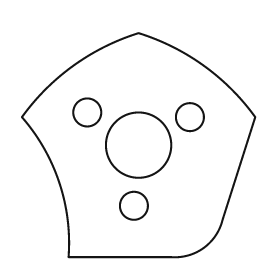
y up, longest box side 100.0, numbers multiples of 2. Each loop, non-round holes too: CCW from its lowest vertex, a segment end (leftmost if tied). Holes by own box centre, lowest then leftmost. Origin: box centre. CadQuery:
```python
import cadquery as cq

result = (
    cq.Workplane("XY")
    .moveTo(-30.0, -48.0)
    .lineTo(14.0, -48.0)
    .threePointArc((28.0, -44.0), (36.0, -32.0))
    .lineTo(50.0, 12.0)
    .threePointArc((28.0, 34.0), (0.0, 48.0))
    .threePointArc((-28.0, 34.0), (-50.0, 12.0))
    .threePointArc((-34.0, -16.0), (-30.0, -48.0))
    .close()
    .moveTo(-2.0, -26.0)
    .circle(6.0)
    .moveTo(0.0, 0.0)
    .circle(14.0)
    .moveTo(22.0, 12.0)
    .circle(6.0)
    .moveTo(-22.0, 14.0)
    .circle(6.0)
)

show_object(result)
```